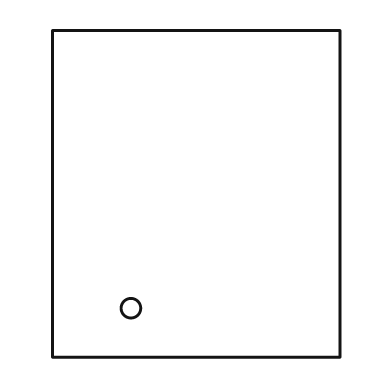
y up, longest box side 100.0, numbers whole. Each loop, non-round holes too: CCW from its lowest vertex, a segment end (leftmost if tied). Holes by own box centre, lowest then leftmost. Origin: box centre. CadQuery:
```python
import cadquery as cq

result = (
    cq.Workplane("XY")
    .moveTo(-44.0, -50.0)
    .lineTo(44.0, -50.0)
    .lineTo(44.0, 50.0)
    .lineTo(-44.0, 50.0)
    .close()
    .moveTo(-20.0, -35.0)
    .circle(3.0)
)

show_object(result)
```